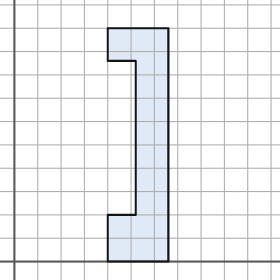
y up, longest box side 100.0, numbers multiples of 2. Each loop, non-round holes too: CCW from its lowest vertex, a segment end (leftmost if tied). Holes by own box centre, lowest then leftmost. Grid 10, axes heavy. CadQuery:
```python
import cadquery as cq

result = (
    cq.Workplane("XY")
    .moveTo(40.0, 0.0)
    .lineTo(66.0, 0.0)
    .lineTo(66.0, 100.0)
    .lineTo(40.0, 100.0)
    .lineTo(40.0, 86.0)
    .lineTo(52.0, 86.0)
    .lineTo(52.0, 20.0)
    .lineTo(40.0, 20.0)
    .close()
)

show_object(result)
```